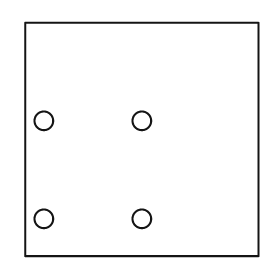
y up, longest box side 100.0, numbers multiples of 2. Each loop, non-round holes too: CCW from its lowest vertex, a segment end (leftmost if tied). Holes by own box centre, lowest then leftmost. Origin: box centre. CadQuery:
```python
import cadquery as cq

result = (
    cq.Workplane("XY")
    .moveTo(-50.0, -50.0)
    .lineTo(50.0, -50.0)
    .lineTo(50.0, 50.0)
    .lineTo(-50.0, 50.0)
    .close()
    .moveTo(-42.0, -34.0)
    .circle(4.0)
    .moveTo(0.0, -34.0)
    .circle(4.0)
    .moveTo(-42.0, 8.0)
    .circle(4.0)
    .moveTo(0.0, 8.0)
    .circle(4.0)
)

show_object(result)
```